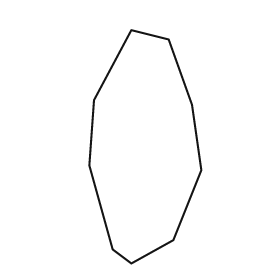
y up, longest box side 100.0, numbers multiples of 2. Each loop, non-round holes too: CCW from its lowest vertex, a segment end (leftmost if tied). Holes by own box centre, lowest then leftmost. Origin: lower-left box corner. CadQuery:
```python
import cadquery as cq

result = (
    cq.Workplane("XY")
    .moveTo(18.0, 0.0)
    .lineTo(36.0, 10.0)
    .lineTo(48.0, 40.0)
    .lineTo(44.0, 68.0)
    .lineTo(34.0, 96.0)
    .lineTo(18.0, 100.0)
    .lineTo(2.0, 70.0)
    .lineTo(0.0, 42.0)
    .lineTo(10.0, 6.0)
    .close()
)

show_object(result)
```